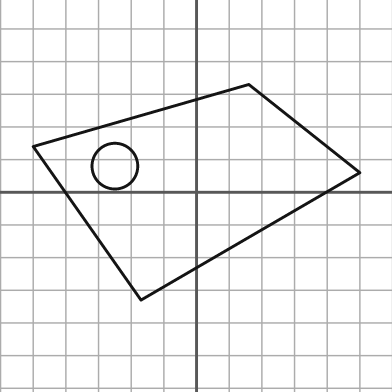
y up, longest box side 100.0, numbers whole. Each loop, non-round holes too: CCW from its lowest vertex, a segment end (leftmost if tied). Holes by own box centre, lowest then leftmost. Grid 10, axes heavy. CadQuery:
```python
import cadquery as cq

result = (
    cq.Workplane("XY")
    .moveTo(-17.0, -33.0)
    .lineTo(50.0, 6.0)
    .lineTo(16.0, 33.0)
    .lineTo(-50.0, 14.0)
    .close()
    .moveTo(-25.0, 8.0)
    .circle(7.0)
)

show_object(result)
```